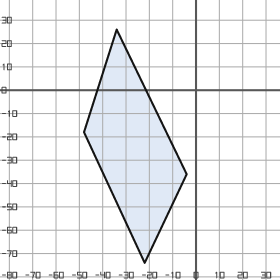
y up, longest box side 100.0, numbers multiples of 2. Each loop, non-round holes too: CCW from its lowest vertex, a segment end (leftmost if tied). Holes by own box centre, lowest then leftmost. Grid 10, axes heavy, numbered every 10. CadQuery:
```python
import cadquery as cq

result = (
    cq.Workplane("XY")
    .moveTo(-22.0, -74.0)
    .lineTo(-4.0, -36.0)
    .lineTo(-34.0, 26.0)
    .lineTo(-48.0, -18.0)
    .close()
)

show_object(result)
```